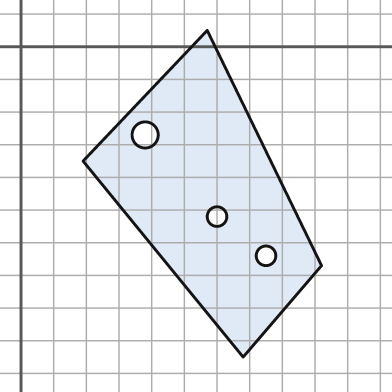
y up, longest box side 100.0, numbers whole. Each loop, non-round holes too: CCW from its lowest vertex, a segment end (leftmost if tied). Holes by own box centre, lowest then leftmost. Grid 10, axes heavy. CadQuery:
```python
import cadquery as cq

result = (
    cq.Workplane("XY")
    .moveTo(68.0, -95.0)
    .lineTo(92.0, -67.0)
    .lineTo(57.0, 5.0)
    .lineTo(19.0, -35.0)
    .close()
    .moveTo(75.0, -64.0)
    .circle(3.0)
    .moveTo(60.0, -52.0)
    .circle(3.0)
    .moveTo(38.0, -27.0)
    .circle(4.0)
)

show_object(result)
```